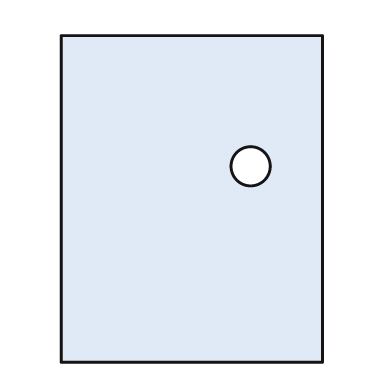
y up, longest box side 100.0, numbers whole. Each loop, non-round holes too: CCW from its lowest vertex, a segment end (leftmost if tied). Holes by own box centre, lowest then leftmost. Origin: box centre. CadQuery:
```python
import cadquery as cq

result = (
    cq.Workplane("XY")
    .moveTo(-40.0, -50.0)
    .lineTo(40.0, -50.0)
    .lineTo(40.0, 50.0)
    .lineTo(-40.0, 50.0)
    .close()
    .moveTo(18.0, 10.0)
    .circle(6.0)
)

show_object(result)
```